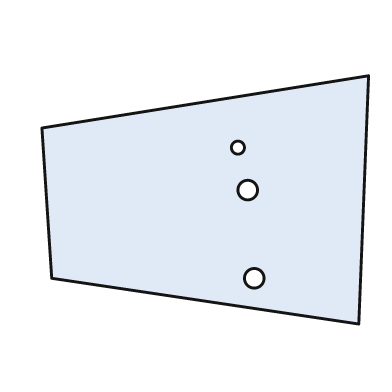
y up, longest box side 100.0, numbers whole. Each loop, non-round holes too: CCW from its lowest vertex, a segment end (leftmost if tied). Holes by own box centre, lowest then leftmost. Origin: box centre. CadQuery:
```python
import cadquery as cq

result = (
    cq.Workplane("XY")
    .moveTo(47.0, -38.0)
    .lineTo(50.0, 38.0)
    .lineTo(-50.0, 22.0)
    .lineTo(-47.0, -24.0)
    .close()
    .moveTo(15.0, -24.0)
    .circle(3.0)
    .moveTo(13.0, 3.0)
    .circle(3.0)
    .moveTo(10.0, 16.0)
    .circle(2.0)
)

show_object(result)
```